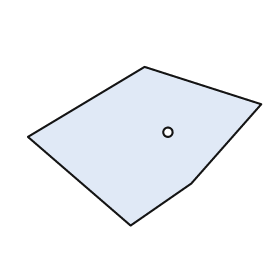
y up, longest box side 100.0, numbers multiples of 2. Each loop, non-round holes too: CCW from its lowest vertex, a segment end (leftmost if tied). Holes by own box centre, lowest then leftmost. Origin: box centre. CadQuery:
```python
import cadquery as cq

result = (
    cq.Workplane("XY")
    .moveTo(-6.0, -34.0)
    .lineTo(20.0, -16.0)
    .lineTo(50.0, 18.0)
    .lineTo(0.0, 34.0)
    .lineTo(-50.0, 4.0)
    .close()
    .moveTo(10.0, 6.0)
    .circle(2.0)
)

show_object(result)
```